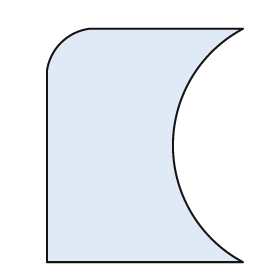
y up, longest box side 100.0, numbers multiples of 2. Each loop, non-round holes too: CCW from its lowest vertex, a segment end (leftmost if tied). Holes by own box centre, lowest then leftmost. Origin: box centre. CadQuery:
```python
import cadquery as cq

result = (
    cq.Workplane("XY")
    .moveTo(-42.0, -50.0)
    .lineTo(42.0, -50.0)
    .threePointArc((12.0, 0.0), (42.0, 50.0))
    .lineTo(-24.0, 50.0)
    .threePointArc((-36.0, 44.0), (-42.0, 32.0))
    .close()
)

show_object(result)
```